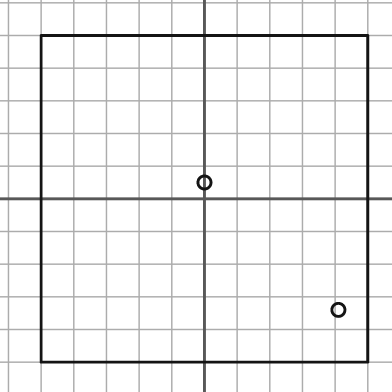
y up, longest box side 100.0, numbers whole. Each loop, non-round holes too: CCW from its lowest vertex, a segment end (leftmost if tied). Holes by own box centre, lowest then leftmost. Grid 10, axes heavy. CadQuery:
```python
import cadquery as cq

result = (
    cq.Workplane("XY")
    .moveTo(-50.0, -50.0)
    .lineTo(50.0, -50.0)
    .lineTo(50.0, 50.0)
    .lineTo(-50.0, 50.0)
    .close()
    .moveTo(41.0, -34.0)
    .circle(2.0)
    .moveTo(0.0, 5.0)
    .circle(2.0)
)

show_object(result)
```